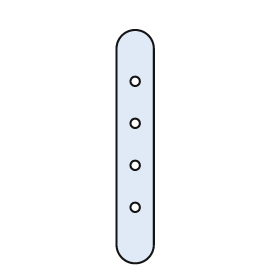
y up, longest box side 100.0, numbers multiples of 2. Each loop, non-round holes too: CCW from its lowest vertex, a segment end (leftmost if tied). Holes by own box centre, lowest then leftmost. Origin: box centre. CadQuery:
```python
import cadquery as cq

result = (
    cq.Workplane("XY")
    .moveTo(-8.0, -42.0)
    .threePointArc((0.0, -50.0), (8.0, -42.0))
    .lineTo(8.0, 42.0)
    .threePointArc((0.0, 50.0), (-8.0, 42.0))
    .close()
    .moveTo(0.0, -26.0)
    .circle(2.0)
    .moveTo(0.0, -8.0)
    .circle(2.0)
    .moveTo(0.0, 10.0)
    .circle(2.0)
    .moveTo(0.0, 28.0)
    .circle(2.0)
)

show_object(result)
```